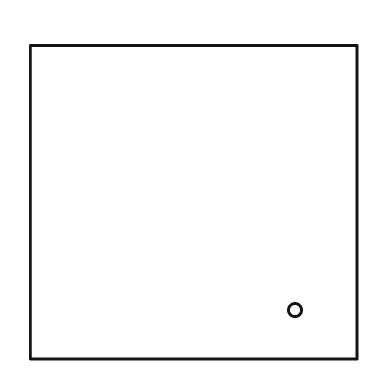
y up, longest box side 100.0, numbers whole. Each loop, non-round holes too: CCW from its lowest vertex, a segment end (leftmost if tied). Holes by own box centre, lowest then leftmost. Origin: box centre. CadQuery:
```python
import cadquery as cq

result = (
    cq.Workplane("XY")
    .moveTo(-50.0, -48.0)
    .lineTo(50.0, -48.0)
    .lineTo(50.0, 48.0)
    .lineTo(-50.0, 48.0)
    .close()
    .moveTo(31.0, -33.0)
    .circle(2.0)
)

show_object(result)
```